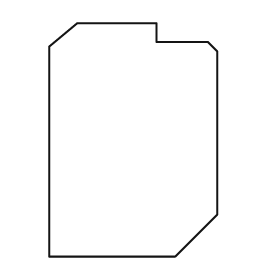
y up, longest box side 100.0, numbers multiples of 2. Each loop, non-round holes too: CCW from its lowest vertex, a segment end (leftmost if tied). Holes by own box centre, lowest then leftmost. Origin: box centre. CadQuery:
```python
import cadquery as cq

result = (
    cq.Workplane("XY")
    .moveTo(-36.0, -50.0)
    .lineTo(18.0, -50.0)
    .lineTo(36.0, -32.0)
    .lineTo(36.0, 38.0)
    .lineTo(32.0, 42.0)
    .lineTo(10.0, 42.0)
    .lineTo(10.0, 50.0)
    .lineTo(-24.0, 50.0)
    .lineTo(-36.0, 40.0)
    .close()
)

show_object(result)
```